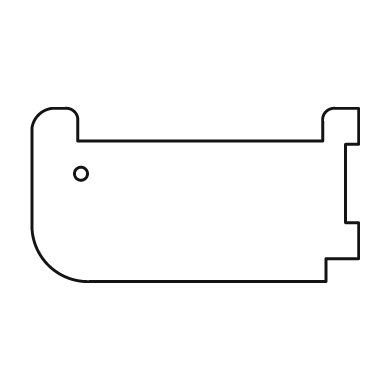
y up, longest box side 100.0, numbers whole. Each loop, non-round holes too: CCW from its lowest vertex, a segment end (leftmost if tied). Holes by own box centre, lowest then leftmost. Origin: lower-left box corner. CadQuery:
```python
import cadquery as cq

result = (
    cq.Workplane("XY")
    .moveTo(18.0, 0.0)
    .lineTo(90.0, 0.0)
    .lineTo(90.0, 7.0)
    .lineTo(100.0, 7.0)
    .lineTo(100.0, 18.0)
    .lineTo(96.0, 18.0)
    .lineTo(96.0, 42.0)
    .lineTo(100.0, 42.0)
    .lineTo(100.0, 53.0)
    .lineTo(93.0, 53.0)
    .threePointArc((90.0, 52.0), (89.0, 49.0))
    .lineTo(89.0, 43.0)
    .lineTo(14.0, 43.0)
    .lineTo(14.0, 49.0)
    .threePointArc((13.0, 52.0), (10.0, 53.0))
    .lineTo(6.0, 53.0)
    .threePointArc((2.0, 51.0), (0.0, 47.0))
    .lineTo(0.0, 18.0)
    .threePointArc((5.0, 5.0), (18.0, 0.0))
    .close()
    .moveTo(15.0, 33.0)
    .circle(2.0)
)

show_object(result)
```